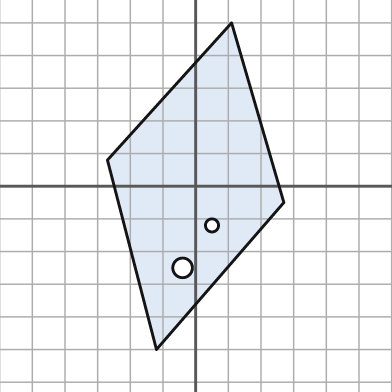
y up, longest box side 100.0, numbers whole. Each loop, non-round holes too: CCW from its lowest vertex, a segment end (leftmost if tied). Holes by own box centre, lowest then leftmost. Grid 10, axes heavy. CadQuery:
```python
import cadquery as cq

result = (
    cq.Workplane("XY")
    .moveTo(-12.0, -50.0)
    .lineTo(27.0, -5.0)
    .lineTo(11.0, 50.0)
    .lineTo(-27.0, 8.0)
    .close()
    .moveTo(-4.0, -25.0)
    .circle(3.0)
    .moveTo(5.0, -12.0)
    .circle(2.0)
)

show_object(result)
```